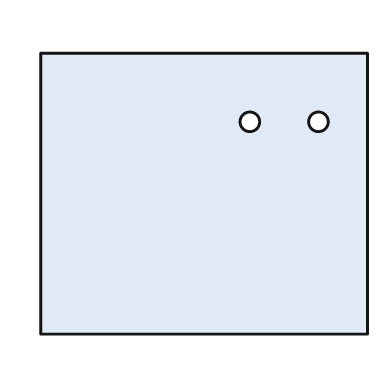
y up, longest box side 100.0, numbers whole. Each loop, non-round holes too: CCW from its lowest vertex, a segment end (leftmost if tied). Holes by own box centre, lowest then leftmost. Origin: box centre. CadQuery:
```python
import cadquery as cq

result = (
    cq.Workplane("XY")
    .moveTo(-50.0, -43.0)
    .lineTo(50.0, -43.0)
    .lineTo(50.0, 43.0)
    .lineTo(-50.0, 43.0)
    .close()
    .moveTo(14.0, 22.0)
    .circle(3.0)
    .moveTo(35.0, 22.0)
    .circle(3.0)
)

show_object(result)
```